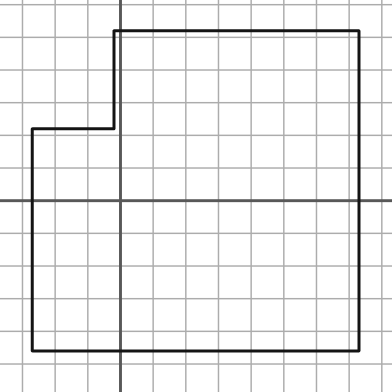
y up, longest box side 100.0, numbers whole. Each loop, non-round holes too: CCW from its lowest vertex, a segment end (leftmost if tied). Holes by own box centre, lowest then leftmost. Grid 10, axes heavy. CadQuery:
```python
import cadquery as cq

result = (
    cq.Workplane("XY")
    .moveTo(-27.0, -46.0)
    .lineTo(73.0, -46.0)
    .lineTo(73.0, 52.0)
    .lineTo(-2.0, 52.0)
    .lineTo(-2.0, 22.0)
    .lineTo(-27.0, 22.0)
    .close()
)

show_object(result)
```